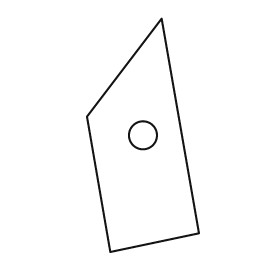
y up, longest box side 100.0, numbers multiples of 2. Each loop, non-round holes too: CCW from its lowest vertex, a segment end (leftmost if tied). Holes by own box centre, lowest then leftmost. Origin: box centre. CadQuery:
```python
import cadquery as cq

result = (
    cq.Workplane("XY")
    .moveTo(-14.0, -50.0)
    .lineTo(24.0, -42.0)
    .lineTo(8.0, 50.0)
    .lineTo(-24.0, 8.0)
    .close()
    .moveTo(0.0, 0.0)
    .circle(6.0)
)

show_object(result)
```